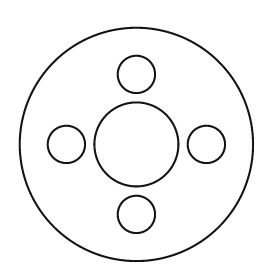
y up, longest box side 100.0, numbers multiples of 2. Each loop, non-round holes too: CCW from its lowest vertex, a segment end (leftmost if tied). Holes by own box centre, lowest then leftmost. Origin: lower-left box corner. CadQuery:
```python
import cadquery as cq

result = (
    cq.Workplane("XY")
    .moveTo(50.0, 50.0)
    .circle(50.0)
    .moveTo(50.0, 20.0)
    .circle(8.0)
    .moveTo(20.0, 50.0)
    .circle(8.0)
    .moveTo(50.0, 50.0)
    .circle(18.0)
    .moveTo(80.0, 50.0)
    .circle(8.0)
    .moveTo(50.0, 80.0)
    .circle(8.0)
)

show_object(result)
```